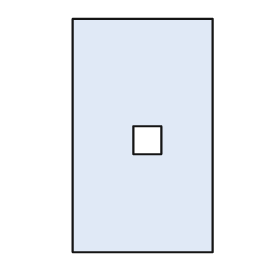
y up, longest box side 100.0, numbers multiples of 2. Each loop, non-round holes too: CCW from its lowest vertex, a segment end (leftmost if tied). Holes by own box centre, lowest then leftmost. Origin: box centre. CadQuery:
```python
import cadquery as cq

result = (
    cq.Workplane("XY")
    .moveTo(-30.0, -50.0)
    .lineTo(30.0, -50.0)
    .lineTo(30.0, 50.0)
    .lineTo(-30.0, 50.0)
    .close()
    .moveTo(-4.0, -8.0)
    .lineTo(8.0, -8.0)
    .lineTo(8.0, 4.0)
    .lineTo(-4.0, 4.0)
    .close()
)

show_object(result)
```